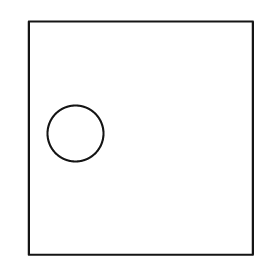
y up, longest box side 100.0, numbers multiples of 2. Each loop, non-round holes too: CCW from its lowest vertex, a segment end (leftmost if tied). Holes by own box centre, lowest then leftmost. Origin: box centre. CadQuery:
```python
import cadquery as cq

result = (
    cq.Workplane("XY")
    .moveTo(-48.0, -50.0)
    .lineTo(48.0, -50.0)
    .lineTo(48.0, 50.0)
    .lineTo(-48.0, 50.0)
    .close()
    .moveTo(-28.0, 2.0)
    .circle(12.0)
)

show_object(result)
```